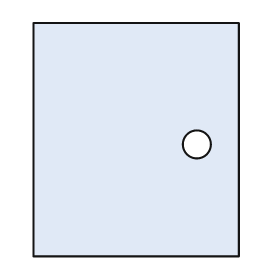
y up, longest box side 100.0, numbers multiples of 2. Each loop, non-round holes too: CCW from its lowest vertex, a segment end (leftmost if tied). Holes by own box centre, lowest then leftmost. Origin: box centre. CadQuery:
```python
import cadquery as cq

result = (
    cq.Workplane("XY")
    .moveTo(-44.0, -50.0)
    .lineTo(44.0, -50.0)
    .lineTo(44.0, 50.0)
    .lineTo(-44.0, 50.0)
    .close()
    .moveTo(26.0, -2.0)
    .circle(6.0)
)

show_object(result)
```